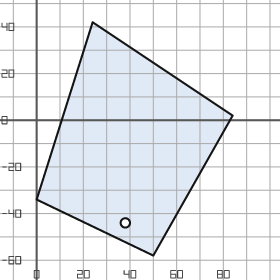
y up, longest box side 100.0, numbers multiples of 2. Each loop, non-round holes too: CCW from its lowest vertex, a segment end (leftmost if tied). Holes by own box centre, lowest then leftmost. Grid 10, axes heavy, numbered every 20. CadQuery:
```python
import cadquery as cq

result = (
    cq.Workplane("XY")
    .moveTo(50.0, -58.0)
    .lineTo(84.0, 2.0)
    .lineTo(24.0, 42.0)
    .lineTo(0.0, -34.0)
    .close()
    .moveTo(38.0, -44.0)
    .circle(2.0)
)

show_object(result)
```